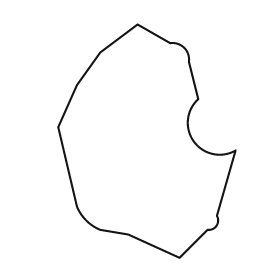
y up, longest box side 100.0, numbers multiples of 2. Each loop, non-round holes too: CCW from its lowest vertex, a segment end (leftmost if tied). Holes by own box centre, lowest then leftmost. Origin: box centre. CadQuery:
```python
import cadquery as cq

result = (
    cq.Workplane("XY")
    .moveTo(14.0, -50.0)
    .lineTo(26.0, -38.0)
    .threePointArc((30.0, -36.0), (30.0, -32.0))
    .lineTo(38.0, -4.0)
    .threePointArc((20.0, 0.0), (22.0, 18.0))
    .lineTo(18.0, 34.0)
    .threePointArc((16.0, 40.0), (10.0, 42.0))
    .lineTo(-4.0, 50.0)
    .lineTo(-20.0, 38.0)
    .lineTo(-30.0, 24.0)
    .lineTo(-38.0, 6.0)
    .lineTo(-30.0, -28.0)
    .threePointArc((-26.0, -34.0), (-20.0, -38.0))
    .lineTo(-8.0, -40.0)
    .close()
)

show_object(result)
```